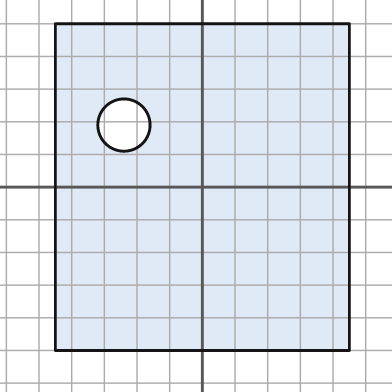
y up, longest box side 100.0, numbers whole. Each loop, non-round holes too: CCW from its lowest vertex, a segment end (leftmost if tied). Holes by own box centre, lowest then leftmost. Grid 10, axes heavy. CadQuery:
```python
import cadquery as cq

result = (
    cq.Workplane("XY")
    .moveTo(-45.0, -50.0)
    .lineTo(45.0, -50.0)
    .lineTo(45.0, 50.0)
    .lineTo(-45.0, 50.0)
    .close()
    .moveTo(-24.0, 19.0)
    .circle(8.0)
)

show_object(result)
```